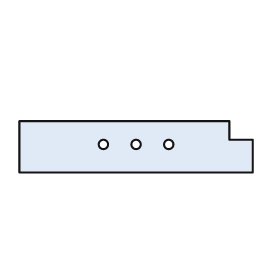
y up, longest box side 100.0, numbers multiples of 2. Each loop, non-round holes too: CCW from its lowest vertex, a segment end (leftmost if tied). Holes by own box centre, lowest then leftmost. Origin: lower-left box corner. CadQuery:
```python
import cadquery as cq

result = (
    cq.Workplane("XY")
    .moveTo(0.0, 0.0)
    .lineTo(100.0, 0.0)
    .lineTo(100.0, 14.0)
    .lineTo(90.0, 14.0)
    .lineTo(90.0, 22.0)
    .lineTo(0.0, 22.0)
    .close()
    .moveTo(36.0, 12.0)
    .circle(2.0)
    .moveTo(50.0, 12.0)
    .circle(2.0)
    .moveTo(64.0, 12.0)
    .circle(2.0)
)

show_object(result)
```